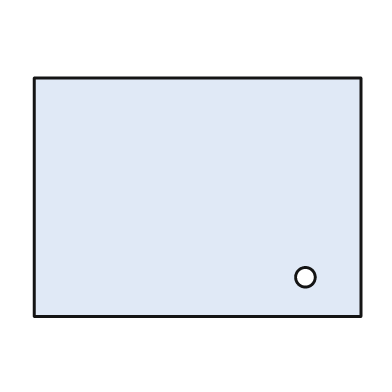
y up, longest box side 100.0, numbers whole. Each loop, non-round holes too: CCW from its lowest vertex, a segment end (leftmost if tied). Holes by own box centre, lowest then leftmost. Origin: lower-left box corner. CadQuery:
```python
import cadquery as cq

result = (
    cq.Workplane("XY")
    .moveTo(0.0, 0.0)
    .lineTo(100.0, 0.0)
    .lineTo(100.0, 73.0)
    .lineTo(0.0, 73.0)
    .close()
    .moveTo(83.0, 12.0)
    .circle(3.0)
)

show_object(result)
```